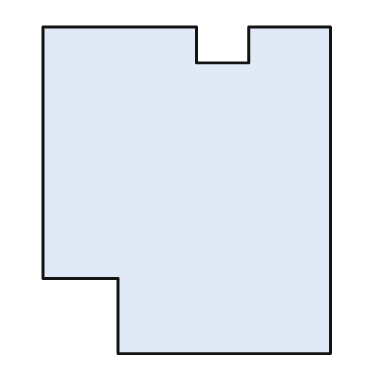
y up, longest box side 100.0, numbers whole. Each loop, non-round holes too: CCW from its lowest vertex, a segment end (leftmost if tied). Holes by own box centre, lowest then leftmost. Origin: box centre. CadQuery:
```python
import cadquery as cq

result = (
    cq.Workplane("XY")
    .moveTo(-21.0, -50.0)
    .lineTo(44.0, -50.0)
    .lineTo(44.0, 50.0)
    .lineTo(19.0, 50.0)
    .lineTo(19.0, 39.0)
    .lineTo(3.0, 39.0)
    .lineTo(3.0, 50.0)
    .lineTo(-44.0, 50.0)
    .lineTo(-44.0, -27.0)
    .lineTo(-21.0, -27.0)
    .close()
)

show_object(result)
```